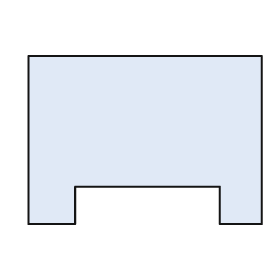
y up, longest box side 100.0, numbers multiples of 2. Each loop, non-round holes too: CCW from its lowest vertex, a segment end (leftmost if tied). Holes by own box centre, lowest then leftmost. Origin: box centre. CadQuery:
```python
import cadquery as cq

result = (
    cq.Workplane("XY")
    .moveTo(-50.0, -36.0)
    .lineTo(-30.0, -36.0)
    .lineTo(-30.0, -20.0)
    .lineTo(32.0, -20.0)
    .lineTo(32.0, -36.0)
    .lineTo(50.0, -36.0)
    .lineTo(50.0, 36.0)
    .lineTo(-50.0, 36.0)
    .close()
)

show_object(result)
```